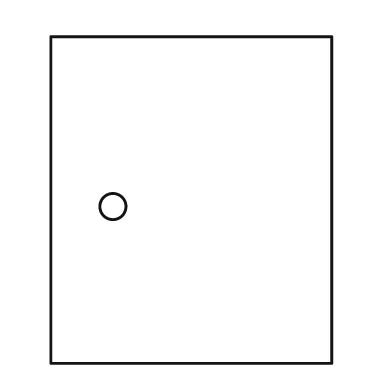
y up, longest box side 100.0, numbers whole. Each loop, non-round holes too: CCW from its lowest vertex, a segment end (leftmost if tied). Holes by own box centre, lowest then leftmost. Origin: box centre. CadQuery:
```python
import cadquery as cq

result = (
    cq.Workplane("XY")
    .moveTo(-43.0, -50.0)
    .lineTo(43.0, -50.0)
    .lineTo(43.0, 50.0)
    .lineTo(-43.0, 50.0)
    .close()
    .moveTo(-24.0, -2.0)
    .circle(4.0)
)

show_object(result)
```